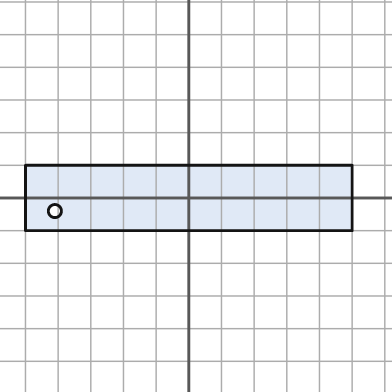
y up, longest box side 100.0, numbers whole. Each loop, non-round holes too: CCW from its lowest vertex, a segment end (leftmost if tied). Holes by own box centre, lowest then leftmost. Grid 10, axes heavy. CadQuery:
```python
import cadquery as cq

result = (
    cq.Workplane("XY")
    .moveTo(-50.0, -10.0)
    .lineTo(50.0, -10.0)
    .lineTo(50.0, 10.0)
    .lineTo(-50.0, 10.0)
    .close()
    .moveTo(-41.0, -4.0)
    .circle(2.0)
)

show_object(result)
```